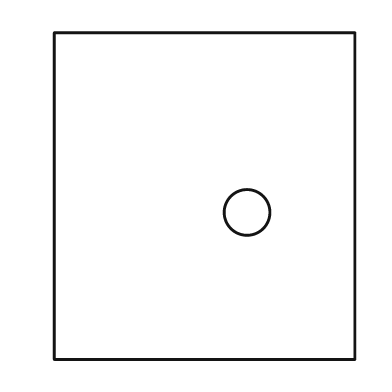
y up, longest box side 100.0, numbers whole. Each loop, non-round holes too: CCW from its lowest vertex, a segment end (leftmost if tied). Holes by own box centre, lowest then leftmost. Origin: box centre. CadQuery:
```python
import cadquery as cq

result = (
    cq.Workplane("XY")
    .moveTo(-46.0, -50.0)
    .lineTo(46.0, -50.0)
    .lineTo(46.0, 50.0)
    .lineTo(-46.0, 50.0)
    .close()
    .moveTo(13.0, -5.0)
    .circle(7.0)
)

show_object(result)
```